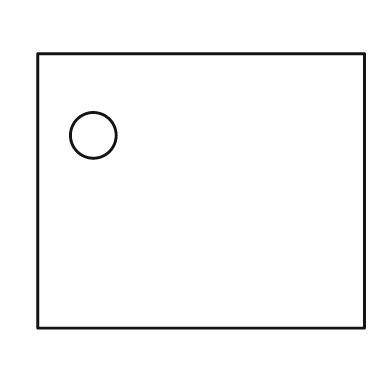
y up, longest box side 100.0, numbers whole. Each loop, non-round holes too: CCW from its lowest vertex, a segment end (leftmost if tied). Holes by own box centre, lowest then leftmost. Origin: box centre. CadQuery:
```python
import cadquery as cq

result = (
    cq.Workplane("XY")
    .moveTo(-50.0, -42.0)
    .lineTo(50.0, -42.0)
    .lineTo(50.0, 42.0)
    .lineTo(-50.0, 42.0)
    .close()
    .moveTo(-33.0, 17.0)
    .circle(7.0)
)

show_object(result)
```